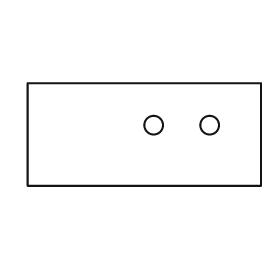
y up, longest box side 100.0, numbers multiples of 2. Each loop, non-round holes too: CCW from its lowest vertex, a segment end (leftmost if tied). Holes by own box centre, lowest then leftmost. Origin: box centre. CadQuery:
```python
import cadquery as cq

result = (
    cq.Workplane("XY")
    .moveTo(-50.0, -22.0)
    .lineTo(50.0, -22.0)
    .lineTo(50.0, 22.0)
    .lineTo(-50.0, 22.0)
    .close()
    .moveTo(4.0, 4.0)
    .circle(4.0)
    .moveTo(28.0, 4.0)
    .circle(4.0)
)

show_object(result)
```